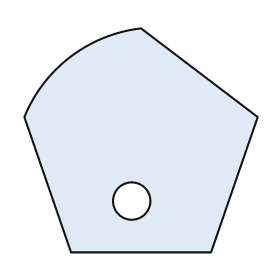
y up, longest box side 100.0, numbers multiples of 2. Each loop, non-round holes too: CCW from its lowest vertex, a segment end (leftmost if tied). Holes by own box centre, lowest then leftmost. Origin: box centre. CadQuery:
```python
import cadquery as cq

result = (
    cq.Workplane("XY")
    .moveTo(-30.0, -48.0)
    .lineTo(30.0, -48.0)
    .lineTo(50.0, 10.0)
    .lineTo(0.0, 48.0)
    .threePointArc((-30.0, 36.0), (-50.0, 10.0))
    .close()
    .moveTo(-4.0, -26.0)
    .circle(8.0)
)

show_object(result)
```